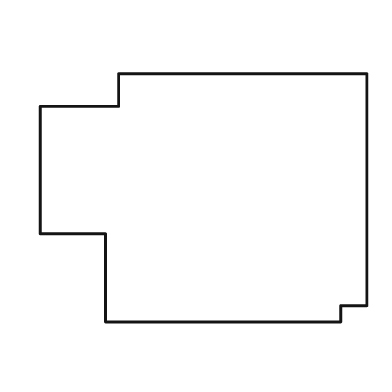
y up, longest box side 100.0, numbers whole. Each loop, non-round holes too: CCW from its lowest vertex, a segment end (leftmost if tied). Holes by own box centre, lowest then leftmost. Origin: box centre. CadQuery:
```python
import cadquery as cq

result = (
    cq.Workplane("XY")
    .moveTo(-30.0, -38.0)
    .lineTo(42.0, -38.0)
    .lineTo(42.0, -33.0)
    .lineTo(50.0, -33.0)
    .lineTo(50.0, 38.0)
    .lineTo(-26.0, 38.0)
    .lineTo(-26.0, 28.0)
    .lineTo(-50.0, 28.0)
    .lineTo(-50.0, -11.0)
    .lineTo(-30.0, -11.0)
    .close()
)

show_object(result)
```